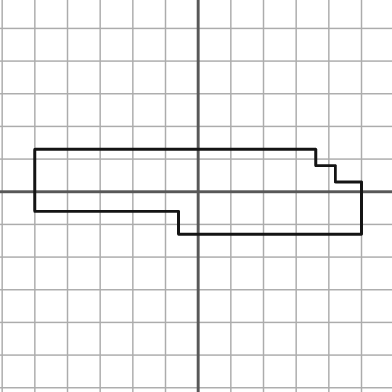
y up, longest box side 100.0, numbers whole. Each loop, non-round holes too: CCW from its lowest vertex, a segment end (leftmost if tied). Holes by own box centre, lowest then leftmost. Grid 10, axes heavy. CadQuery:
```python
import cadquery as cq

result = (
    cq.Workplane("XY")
    .moveTo(-6.0, -13.0)
    .lineTo(50.0, -13.0)
    .lineTo(50.0, 3.0)
    .lineTo(42.0, 3.0)
    .lineTo(42.0, 8.0)
    .lineTo(36.0, 8.0)
    .lineTo(36.0, 13.0)
    .lineTo(-50.0, 13.0)
    .lineTo(-50.0, -6.0)
    .lineTo(-6.0, -6.0)
    .close()
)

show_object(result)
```